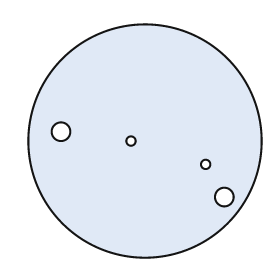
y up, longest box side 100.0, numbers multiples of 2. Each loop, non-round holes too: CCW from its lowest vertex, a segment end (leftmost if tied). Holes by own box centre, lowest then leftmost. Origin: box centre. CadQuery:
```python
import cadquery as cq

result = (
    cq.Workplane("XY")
    .moveTo(0.0, 0.0)
    .circle(50.0)
    .moveTo(34.0, -24.0)
    .circle(4.0)
    .moveTo(26.0, -10.0)
    .circle(2.0)
    .moveTo(-6.0, 0.0)
    .circle(2.0)
    .moveTo(-36.0, 4.0)
    .circle(4.0)
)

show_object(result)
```